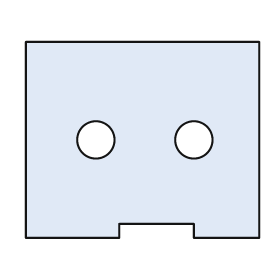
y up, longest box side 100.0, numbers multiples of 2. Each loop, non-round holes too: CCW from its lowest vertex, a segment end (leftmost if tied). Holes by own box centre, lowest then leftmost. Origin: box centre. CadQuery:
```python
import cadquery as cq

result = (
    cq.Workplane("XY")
    .moveTo(-50.0, -42.0)
    .lineTo(-10.0, -42.0)
    .lineTo(-10.0, -36.0)
    .lineTo(22.0, -36.0)
    .lineTo(22.0, -42.0)
    .lineTo(50.0, -42.0)
    .lineTo(50.0, 42.0)
    .lineTo(-50.0, 42.0)
    .close()
    .moveTo(-20.0, 0.0)
    .circle(8.0)
    .moveTo(22.0, 0.0)
    .circle(8.0)
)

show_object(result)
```